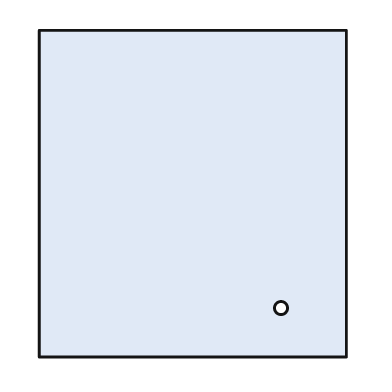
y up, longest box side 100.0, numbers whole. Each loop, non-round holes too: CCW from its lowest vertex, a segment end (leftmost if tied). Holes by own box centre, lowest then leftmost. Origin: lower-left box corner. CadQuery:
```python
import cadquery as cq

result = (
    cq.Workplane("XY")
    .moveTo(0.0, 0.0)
    .lineTo(94.0, 0.0)
    .lineTo(94.0, 100.0)
    .lineTo(0.0, 100.0)
    .close()
    .moveTo(74.0, 15.0)
    .circle(2.0)
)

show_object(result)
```